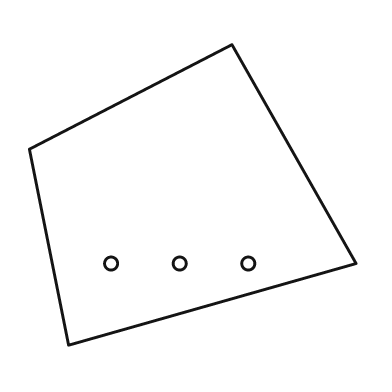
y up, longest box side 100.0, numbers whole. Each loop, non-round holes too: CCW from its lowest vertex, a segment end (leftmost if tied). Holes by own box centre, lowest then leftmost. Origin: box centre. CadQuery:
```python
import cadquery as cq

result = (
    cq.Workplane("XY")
    .moveTo(-38.0, -46.0)
    .lineTo(50.0, -21.0)
    .lineTo(12.0, 46.0)
    .lineTo(-50.0, 14.0)
    .close()
    .moveTo(-25.0, -21.0)
    .circle(2.0)
    .moveTo(-4.0, -21.0)
    .circle(2.0)
    .moveTo(17.0, -21.0)
    .circle(2.0)
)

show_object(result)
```